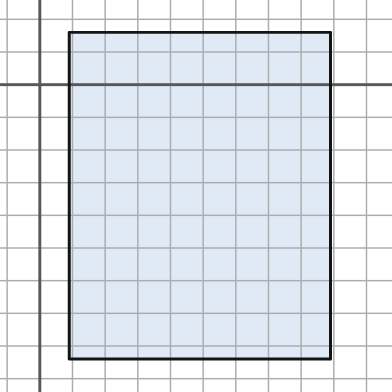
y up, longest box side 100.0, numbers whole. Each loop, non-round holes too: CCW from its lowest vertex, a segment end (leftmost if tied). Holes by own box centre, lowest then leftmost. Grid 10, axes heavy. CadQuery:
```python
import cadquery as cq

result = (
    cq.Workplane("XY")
    .moveTo(9.0, -84.0)
    .lineTo(89.0, -84.0)
    .lineTo(89.0, 16.0)
    .lineTo(9.0, 16.0)
    .close()
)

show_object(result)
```